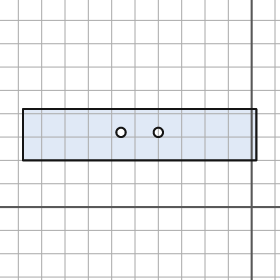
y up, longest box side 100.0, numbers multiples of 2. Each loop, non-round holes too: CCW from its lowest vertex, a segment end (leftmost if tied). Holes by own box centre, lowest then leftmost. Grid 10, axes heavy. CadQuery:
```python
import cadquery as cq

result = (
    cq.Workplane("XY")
    .moveTo(-98.0, 20.0)
    .lineTo(2.0, 20.0)
    .lineTo(2.0, 42.0)
    .lineTo(-98.0, 42.0)
    .close()
    .moveTo(-56.0, 32.0)
    .circle(2.0)
    .moveTo(-40.0, 32.0)
    .circle(2.0)
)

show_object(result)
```